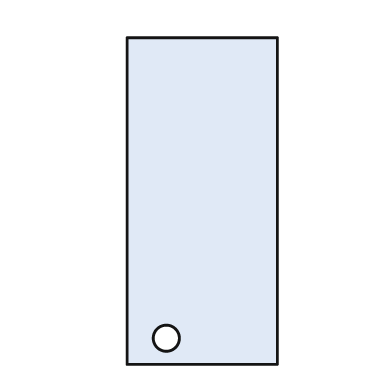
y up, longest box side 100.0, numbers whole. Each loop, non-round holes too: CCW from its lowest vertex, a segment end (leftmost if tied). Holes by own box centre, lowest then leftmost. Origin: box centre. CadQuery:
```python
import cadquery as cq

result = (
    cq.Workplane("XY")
    .moveTo(-23.0, -50.0)
    .lineTo(23.0, -50.0)
    .lineTo(23.0, 50.0)
    .lineTo(-23.0, 50.0)
    .close()
    .moveTo(-11.0, -42.0)
    .circle(4.0)
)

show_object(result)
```